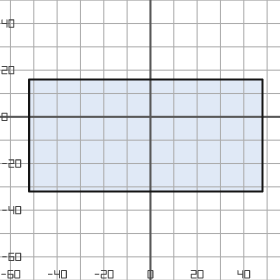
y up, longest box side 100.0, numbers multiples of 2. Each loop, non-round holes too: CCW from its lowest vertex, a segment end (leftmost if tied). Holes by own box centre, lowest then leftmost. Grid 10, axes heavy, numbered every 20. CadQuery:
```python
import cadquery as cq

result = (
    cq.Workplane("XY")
    .moveTo(-52.0, -32.0)
    .lineTo(48.0, -32.0)
    .lineTo(48.0, 16.0)
    .lineTo(-52.0, 16.0)
    .close()
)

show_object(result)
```